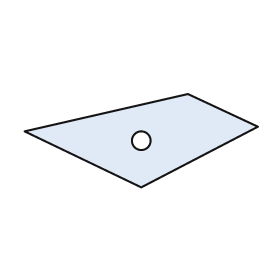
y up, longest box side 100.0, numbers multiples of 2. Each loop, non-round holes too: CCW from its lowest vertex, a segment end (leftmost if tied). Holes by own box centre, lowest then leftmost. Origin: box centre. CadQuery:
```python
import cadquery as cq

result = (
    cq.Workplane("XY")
    .moveTo(0.0, -20.0)
    .lineTo(50.0, 6.0)
    .lineTo(20.0, 20.0)
    .lineTo(-50.0, 4.0)
    .close()
    .moveTo(0.0, 0.0)
    .circle(4.0)
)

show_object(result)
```